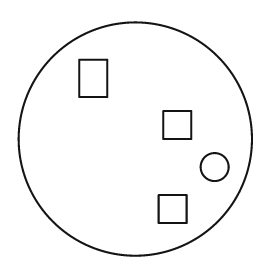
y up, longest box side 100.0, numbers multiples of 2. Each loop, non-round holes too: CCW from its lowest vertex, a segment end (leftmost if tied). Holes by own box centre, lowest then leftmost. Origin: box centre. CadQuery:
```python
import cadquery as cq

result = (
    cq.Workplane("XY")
    .moveTo(0.0, 0.0)
    .circle(50.0)
    .moveTo(10.0, -36.0)
    .lineTo(22.0, -36.0)
    .lineTo(22.0, -24.0)
    .lineTo(10.0, -24.0)
    .close()
    .moveTo(34.0, -12.0)
    .circle(6.0)
    .moveTo(12.0, 0.0)
    .lineTo(24.0, 0.0)
    .lineTo(24.0, 12.0)
    .lineTo(12.0, 12.0)
    .close()
    .moveTo(-24.0, 18.0)
    .lineTo(-12.0, 18.0)
    .lineTo(-12.0, 34.0)
    .lineTo(-24.0, 34.0)
    .close()
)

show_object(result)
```